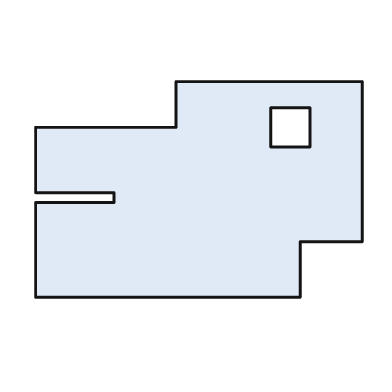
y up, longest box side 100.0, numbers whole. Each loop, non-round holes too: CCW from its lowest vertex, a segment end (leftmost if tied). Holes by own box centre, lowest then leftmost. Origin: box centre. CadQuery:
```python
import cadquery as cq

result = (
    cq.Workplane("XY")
    .moveTo(-50.0, -33.0)
    .lineTo(31.0, -33.0)
    .lineTo(31.0, -16.0)
    .lineTo(50.0, -16.0)
    .lineTo(50.0, 33.0)
    .lineTo(-7.0, 33.0)
    .lineTo(-7.0, 19.0)
    .lineTo(-50.0, 19.0)
    .lineTo(-50.0, -1.0)
    .lineTo(-26.0, -1.0)
    .lineTo(-26.0, -4.0)
    .lineTo(-50.0, -4.0)
    .close()
    .moveTo(22.0, 13.0)
    .lineTo(34.0, 13.0)
    .lineTo(34.0, 25.0)
    .lineTo(22.0, 25.0)
    .close()
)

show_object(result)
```